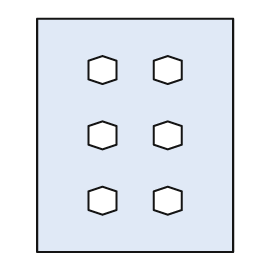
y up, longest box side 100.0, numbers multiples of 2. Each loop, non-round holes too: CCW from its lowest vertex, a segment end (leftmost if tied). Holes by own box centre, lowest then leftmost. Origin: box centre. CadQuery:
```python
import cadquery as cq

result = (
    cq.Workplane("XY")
    .moveTo(-42.0, -50.0)
    .lineTo(42.0, -50.0)
    .lineTo(42.0, 50.0)
    .lineTo(-42.0, 50.0)
    .close()
    .moveTo(-14.0, -34.0)
    .lineTo(-8.0, -32.0)
    .lineTo(-8.0, -24.0)
    .lineTo(-14.0, -22.0)
    .lineTo(-20.0, -24.0)
    .lineTo(-20.0, -32.0)
    .close()
    .moveTo(14.0, -34.0)
    .lineTo(20.0, -32.0)
    .lineTo(20.0, -24.0)
    .lineTo(14.0, -22.0)
    .lineTo(8.0, -24.0)
    .lineTo(8.0, -32.0)
    .close()
    .moveTo(-14.0, -6.0)
    .lineTo(-8.0, -4.0)
    .lineTo(-8.0, 4.0)
    .lineTo(-14.0, 6.0)
    .lineTo(-20.0, 4.0)
    .lineTo(-20.0, -4.0)
    .close()
    .moveTo(14.0, -6.0)
    .lineTo(20.0, -4.0)
    .lineTo(20.0, 4.0)
    .lineTo(14.0, 6.0)
    .lineTo(8.0, 4.0)
    .lineTo(8.0, -4.0)
    .close()
    .moveTo(-14.0, 22.0)
    .lineTo(-8.0, 24.0)
    .lineTo(-8.0, 32.0)
    .lineTo(-14.0, 34.0)
    .lineTo(-20.0, 32.0)
    .lineTo(-20.0, 24.0)
    .close()
    .moveTo(14.0, 22.0)
    .lineTo(20.0, 24.0)
    .lineTo(20.0, 32.0)
    .lineTo(14.0, 34.0)
    .lineTo(8.0, 32.0)
    .lineTo(8.0, 24.0)
    .close()
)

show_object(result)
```